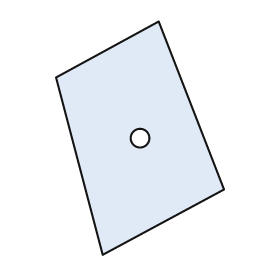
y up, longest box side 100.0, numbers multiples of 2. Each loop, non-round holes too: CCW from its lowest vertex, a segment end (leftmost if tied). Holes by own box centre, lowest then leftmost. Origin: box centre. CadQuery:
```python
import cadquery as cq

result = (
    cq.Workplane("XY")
    .moveTo(-16.0, -50.0)
    .lineTo(36.0, -22.0)
    .lineTo(8.0, 50.0)
    .lineTo(-36.0, 26.0)
    .close()
    .moveTo(0.0, 0.0)
    .circle(4.0)
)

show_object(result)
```